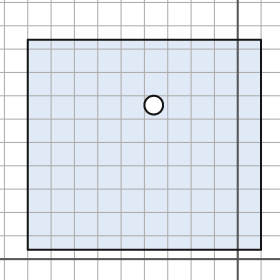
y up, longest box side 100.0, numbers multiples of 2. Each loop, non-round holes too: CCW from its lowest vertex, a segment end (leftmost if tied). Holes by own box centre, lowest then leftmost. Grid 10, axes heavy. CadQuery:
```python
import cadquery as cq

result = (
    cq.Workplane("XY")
    .moveTo(-90.0, 4.0)
    .lineTo(10.0, 4.0)
    .lineTo(10.0, 94.0)
    .lineTo(-90.0, 94.0)
    .close()
    .moveTo(-36.0, 66.0)
    .circle(4.0)
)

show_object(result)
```